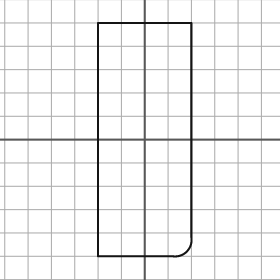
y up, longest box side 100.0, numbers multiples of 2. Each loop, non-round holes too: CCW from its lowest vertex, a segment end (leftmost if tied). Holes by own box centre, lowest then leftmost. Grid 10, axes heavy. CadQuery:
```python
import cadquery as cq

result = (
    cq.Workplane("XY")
    .moveTo(-20.0, -50.0)
    .lineTo(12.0, -50.0)
    .threePointArc((18.0, -48.0), (20.0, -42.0))
    .lineTo(20.0, 50.0)
    .lineTo(-20.0, 50.0)
    .close()
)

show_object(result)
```